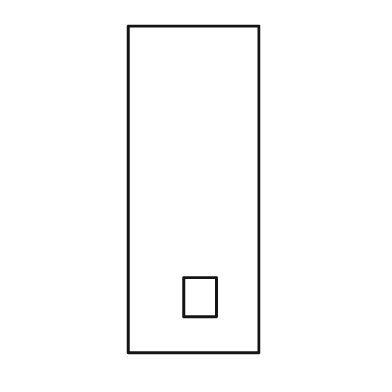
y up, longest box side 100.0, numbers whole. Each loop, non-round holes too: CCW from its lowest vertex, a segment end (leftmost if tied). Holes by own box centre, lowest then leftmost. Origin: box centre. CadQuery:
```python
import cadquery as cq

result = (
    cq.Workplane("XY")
    .moveTo(-20.0, -50.0)
    .lineTo(20.0, -50.0)
    .lineTo(20.0, 50.0)
    .lineTo(-20.0, 50.0)
    .close()
    .moveTo(-3.0, -39.0)
    .lineTo(7.0, -39.0)
    .lineTo(7.0, -27.0)
    .lineTo(-3.0, -27.0)
    .close()
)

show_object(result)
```